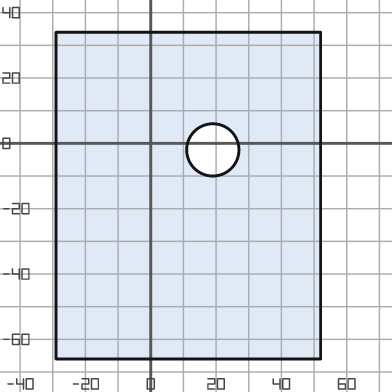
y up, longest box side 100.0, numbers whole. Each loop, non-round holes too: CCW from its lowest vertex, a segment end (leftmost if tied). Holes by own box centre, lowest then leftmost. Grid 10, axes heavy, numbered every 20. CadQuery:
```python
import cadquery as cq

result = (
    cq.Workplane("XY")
    .moveTo(-29.0, -66.0)
    .lineTo(52.0, -66.0)
    .lineTo(52.0, 34.0)
    .lineTo(-29.0, 34.0)
    .close()
    .moveTo(19.0, -2.0)
    .circle(8.0)
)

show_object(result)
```